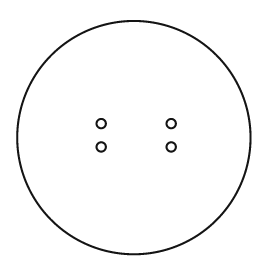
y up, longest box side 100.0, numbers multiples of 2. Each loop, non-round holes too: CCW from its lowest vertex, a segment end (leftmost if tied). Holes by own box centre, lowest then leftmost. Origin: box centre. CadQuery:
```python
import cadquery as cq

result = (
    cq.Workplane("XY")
    .moveTo(0.0, 0.0)
    .circle(50.0)
    .moveTo(-14.0, -4.0)
    .circle(2.0)
    .moveTo(16.0, -4.0)
    .circle(2.0)
    .moveTo(-14.0, 6.0)
    .circle(2.0)
    .moveTo(16.0, 6.0)
    .circle(2.0)
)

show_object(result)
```